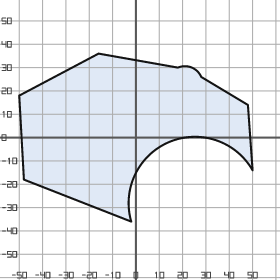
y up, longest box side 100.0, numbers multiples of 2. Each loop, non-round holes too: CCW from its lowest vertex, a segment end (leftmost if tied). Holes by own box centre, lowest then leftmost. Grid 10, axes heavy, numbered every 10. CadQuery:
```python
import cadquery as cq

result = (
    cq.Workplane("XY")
    .moveTo(-2.0, -36.0)
    .threePointArc((14.0, -2.0), (50.0, -14.0))
    .lineTo(48.0, 14.0)
    .lineTo(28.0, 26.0)
    .threePointArc((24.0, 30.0), (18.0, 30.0))
    .lineTo(-16.0, 36.0)
    .lineTo(-50.0, 18.0)
    .lineTo(-48.0, -18.0)
    .close()
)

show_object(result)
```